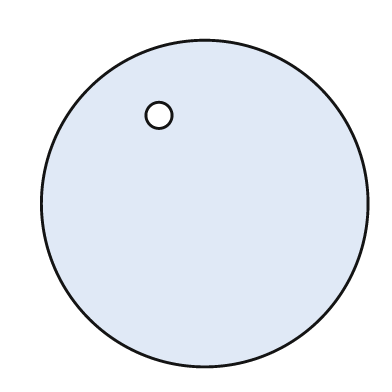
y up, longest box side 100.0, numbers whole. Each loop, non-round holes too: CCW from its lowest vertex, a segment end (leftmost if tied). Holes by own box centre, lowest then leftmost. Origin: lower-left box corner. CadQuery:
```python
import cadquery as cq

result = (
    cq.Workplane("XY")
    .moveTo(50.0, 50.0)
    .circle(50.0)
    .moveTo(36.0, 77.0)
    .circle(4.0)
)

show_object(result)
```